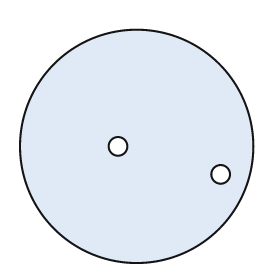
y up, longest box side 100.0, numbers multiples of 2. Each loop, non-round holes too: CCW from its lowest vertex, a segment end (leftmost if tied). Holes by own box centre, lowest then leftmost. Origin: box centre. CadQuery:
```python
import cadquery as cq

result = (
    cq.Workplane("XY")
    .moveTo(0.0, 0.0)
    .circle(50.0)
    .moveTo(36.0, -12.0)
    .circle(4.0)
    .moveTo(-8.0, 0.0)
    .circle(4.0)
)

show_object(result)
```